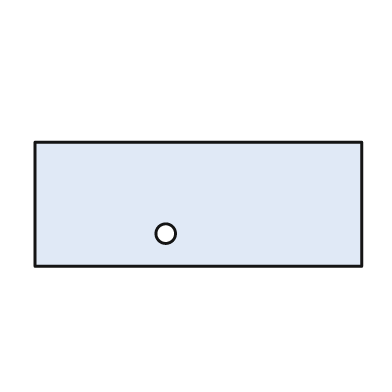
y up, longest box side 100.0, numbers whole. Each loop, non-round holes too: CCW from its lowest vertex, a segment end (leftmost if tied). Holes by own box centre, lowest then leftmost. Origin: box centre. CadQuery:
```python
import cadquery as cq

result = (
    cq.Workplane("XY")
    .moveTo(-50.0, -19.0)
    .lineTo(50.0, -19.0)
    .lineTo(50.0, 19.0)
    .lineTo(-50.0, 19.0)
    .close()
    .moveTo(-10.0, -9.0)
    .circle(3.0)
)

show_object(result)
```